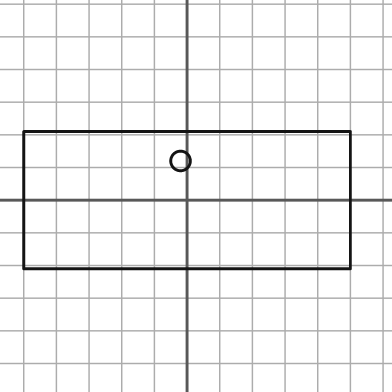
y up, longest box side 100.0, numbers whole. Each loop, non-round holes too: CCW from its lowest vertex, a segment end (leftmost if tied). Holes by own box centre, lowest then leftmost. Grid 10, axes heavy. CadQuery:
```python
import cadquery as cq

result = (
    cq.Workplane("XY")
    .moveTo(-50.0, -21.0)
    .lineTo(50.0, -21.0)
    .lineTo(50.0, 21.0)
    .lineTo(-50.0, 21.0)
    .close()
    .moveTo(-2.0, 12.0)
    .circle(3.0)
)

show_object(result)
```